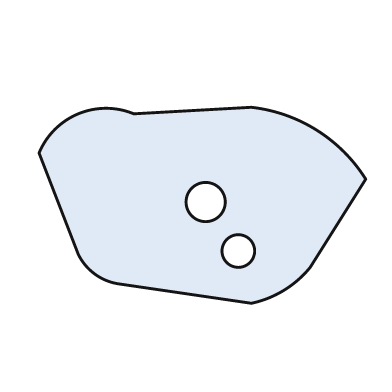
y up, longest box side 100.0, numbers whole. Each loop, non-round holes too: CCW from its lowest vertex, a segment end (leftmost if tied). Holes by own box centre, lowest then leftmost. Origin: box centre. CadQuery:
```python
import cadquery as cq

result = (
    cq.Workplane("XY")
    .moveTo(15.0, -30.0)
    .threePointArc((25.0, -26.0), (33.0, -19.0))
    .lineTo(50.0, 8.0)
    .threePointArc((35.0, 23.0), (15.0, 30.0))
    .lineTo(-21.0, 28.0)
    .threePointArc((-38.0, 28.0), (-50.0, 16.0))
    .lineTo(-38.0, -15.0)
    .threePointArc((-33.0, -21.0), (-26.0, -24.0))
    .close()
    .moveTo(11.0, -14.0)
    .circle(5.0)
    .moveTo(1.0, 1.0)
    .circle(6.0)
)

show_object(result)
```